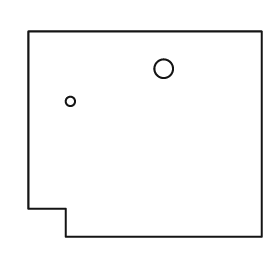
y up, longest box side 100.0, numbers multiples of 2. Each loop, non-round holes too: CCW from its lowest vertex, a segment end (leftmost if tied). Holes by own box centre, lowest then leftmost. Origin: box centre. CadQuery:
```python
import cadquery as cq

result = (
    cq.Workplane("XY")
    .moveTo(-34.0, -44.0)
    .lineTo(50.0, -44.0)
    .lineTo(50.0, 44.0)
    .lineTo(-50.0, 44.0)
    .lineTo(-50.0, -32.0)
    .lineTo(-34.0, -32.0)
    .close()
    .moveTo(-32.0, 14.0)
    .circle(2.0)
    .moveTo(8.0, 28.0)
    .circle(4.0)
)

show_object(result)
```